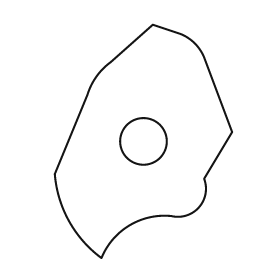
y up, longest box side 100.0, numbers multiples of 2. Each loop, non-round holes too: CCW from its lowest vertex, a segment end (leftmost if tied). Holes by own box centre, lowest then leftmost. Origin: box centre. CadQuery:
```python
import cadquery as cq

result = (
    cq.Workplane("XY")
    .moveTo(-18.0, -50.0)
    .threePointArc((-6.0, -36.0), (12.0, -32.0))
    .threePointArc((24.0, -28.0), (26.0, -16.0))
    .lineTo(38.0, 4.0)
    .lineTo(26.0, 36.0)
    .threePointArc((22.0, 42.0), (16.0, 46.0))
    .lineTo(4.0, 50.0)
    .lineTo(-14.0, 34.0)
    .threePointArc((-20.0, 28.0), (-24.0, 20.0))
    .lineTo(-38.0, -14.0)
    .threePointArc((-32.0, -34.0), (-18.0, -50.0))
    .close()
    .moveTo(0.0, 0.0)
    .circle(10.0)
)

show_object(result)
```